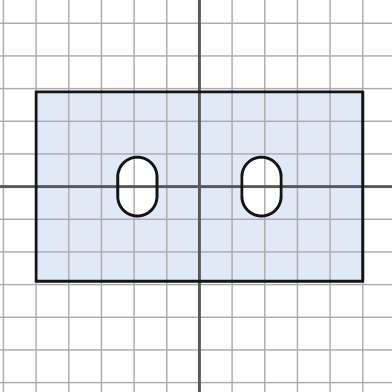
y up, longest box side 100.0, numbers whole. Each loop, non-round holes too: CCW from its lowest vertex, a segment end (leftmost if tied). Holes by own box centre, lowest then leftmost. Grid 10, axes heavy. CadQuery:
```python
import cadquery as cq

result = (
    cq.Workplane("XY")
    .moveTo(-50.0, -29.0)
    .lineTo(50.0, -29.0)
    .lineTo(50.0, 29.0)
    .lineTo(-50.0, 29.0)
    .close()
    .moveTo(-25.0, -3.0)
    .threePointArc((-19.0, -9.0), (-13.0, -3.0))
    .lineTo(-13.0, 3.0)
    .threePointArc((-19.0, 9.0), (-25.0, 3.0))
    .close()
    .moveTo(13.0, -3.0)
    .threePointArc((19.0, -9.0), (25.0, -3.0))
    .lineTo(25.0, 3.0)
    .threePointArc((19.0, 9.0), (13.0, 3.0))
    .close()
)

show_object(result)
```